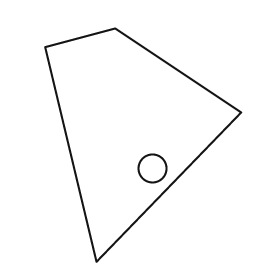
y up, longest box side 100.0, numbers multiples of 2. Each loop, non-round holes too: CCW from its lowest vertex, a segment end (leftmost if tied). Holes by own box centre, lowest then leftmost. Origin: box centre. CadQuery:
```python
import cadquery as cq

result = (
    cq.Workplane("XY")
    .moveTo(-20.0, -50.0)
    .lineTo(42.0, 14.0)
    .lineTo(-12.0, 50.0)
    .lineTo(-42.0, 42.0)
    .close()
    .moveTo(4.0, -10.0)
    .circle(6.0)
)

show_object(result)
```